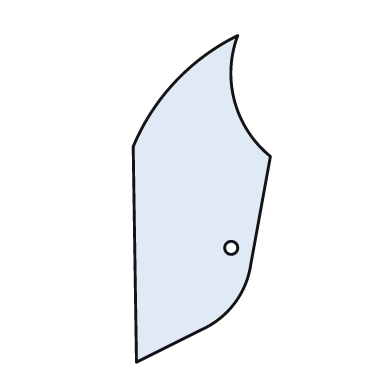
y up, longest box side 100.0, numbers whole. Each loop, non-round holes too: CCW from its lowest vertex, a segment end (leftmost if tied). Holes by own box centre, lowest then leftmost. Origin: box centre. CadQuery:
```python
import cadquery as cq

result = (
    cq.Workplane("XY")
    .moveTo(-20.0, -50.0)
    .lineTo(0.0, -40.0)
    .threePointArc((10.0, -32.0), (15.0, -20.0))
    .lineTo(21.0, 13.0)
    .threePointArc((10.0, 30.0), (11.0, 50.0))
    .threePointArc((-8.0, 36.0), (-21.0, 16.0))
    .close()
    .moveTo(9.0, -15.0)
    .circle(2.0)
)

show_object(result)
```